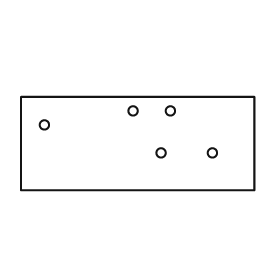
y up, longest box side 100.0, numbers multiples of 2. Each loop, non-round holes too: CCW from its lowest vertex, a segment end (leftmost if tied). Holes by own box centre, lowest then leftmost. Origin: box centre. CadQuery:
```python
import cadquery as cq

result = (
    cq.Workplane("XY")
    .moveTo(-50.0, -20.0)
    .lineTo(50.0, -20.0)
    .lineTo(50.0, 20.0)
    .lineTo(-50.0, 20.0)
    .close()
    .moveTo(10.0, -4.0)
    .circle(2.0)
    .moveTo(32.0, -4.0)
    .circle(2.0)
    .moveTo(-40.0, 8.0)
    .circle(2.0)
    .moveTo(-2.0, 14.0)
    .circle(2.0)
    .moveTo(14.0, 14.0)
    .circle(2.0)
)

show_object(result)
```